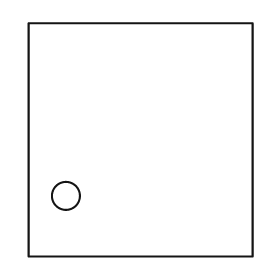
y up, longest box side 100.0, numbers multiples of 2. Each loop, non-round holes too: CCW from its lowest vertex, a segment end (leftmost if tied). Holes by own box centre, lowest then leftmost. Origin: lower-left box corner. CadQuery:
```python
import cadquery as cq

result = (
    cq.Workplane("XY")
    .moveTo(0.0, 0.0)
    .lineTo(96.0, 0.0)
    .lineTo(96.0, 100.0)
    .lineTo(0.0, 100.0)
    .close()
    .moveTo(16.0, 26.0)
    .circle(6.0)
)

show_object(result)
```